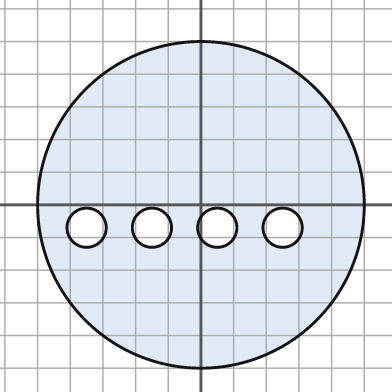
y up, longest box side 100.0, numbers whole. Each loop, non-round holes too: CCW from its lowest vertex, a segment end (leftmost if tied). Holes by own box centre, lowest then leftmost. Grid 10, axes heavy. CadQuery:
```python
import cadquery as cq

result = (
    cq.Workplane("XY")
    .moveTo(0.0, 0.0)
    .circle(50.0)
    .moveTo(-35.0, -7.0)
    .circle(6.0)
    .moveTo(-15.0, -7.0)
    .circle(6.0)
    .moveTo(5.0, -7.0)
    .circle(6.0)
    .moveTo(25.0, -7.0)
    .circle(6.0)
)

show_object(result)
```